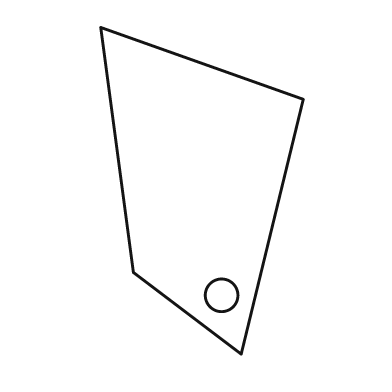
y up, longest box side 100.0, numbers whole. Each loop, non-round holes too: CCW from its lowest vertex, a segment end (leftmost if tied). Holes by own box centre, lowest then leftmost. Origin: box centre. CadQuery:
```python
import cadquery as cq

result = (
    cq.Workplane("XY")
    .moveTo(12.0, -50.0)
    .lineTo(31.0, 28.0)
    .lineTo(-31.0, 50.0)
    .lineTo(-21.0, -25.0)
    .close()
    .moveTo(6.0, -32.0)
    .circle(5.0)
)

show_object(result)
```